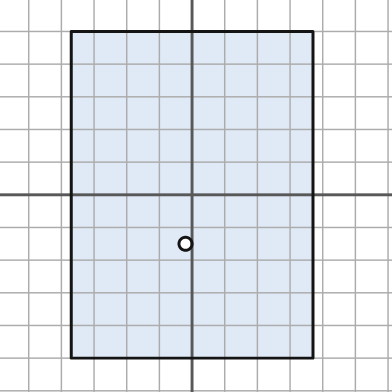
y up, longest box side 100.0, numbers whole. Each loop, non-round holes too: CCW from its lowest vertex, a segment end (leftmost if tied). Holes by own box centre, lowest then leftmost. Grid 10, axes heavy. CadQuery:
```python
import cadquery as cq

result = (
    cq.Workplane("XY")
    .moveTo(-37.0, -50.0)
    .lineTo(37.0, -50.0)
    .lineTo(37.0, 50.0)
    .lineTo(-37.0, 50.0)
    .close()
    .moveTo(-2.0, -15.0)
    .circle(2.0)
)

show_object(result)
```